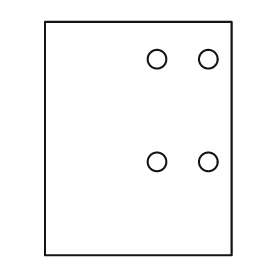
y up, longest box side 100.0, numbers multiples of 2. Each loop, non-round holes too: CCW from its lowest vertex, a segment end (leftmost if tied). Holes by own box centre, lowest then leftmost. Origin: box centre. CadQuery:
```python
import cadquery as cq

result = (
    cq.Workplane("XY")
    .moveTo(-40.0, -50.0)
    .lineTo(40.0, -50.0)
    .lineTo(40.0, 50.0)
    .lineTo(-40.0, 50.0)
    .close()
    .moveTo(8.0, -10.0)
    .circle(4.0)
    .moveTo(30.0, -10.0)
    .circle(4.0)
    .moveTo(8.0, 34.0)
    .circle(4.0)
    .moveTo(30.0, 34.0)
    .circle(4.0)
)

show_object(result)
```